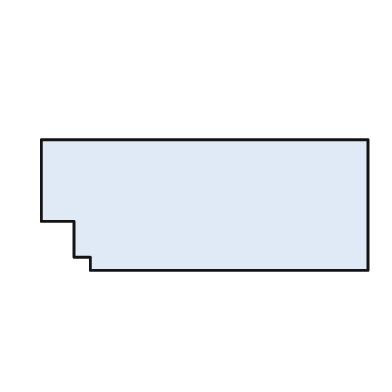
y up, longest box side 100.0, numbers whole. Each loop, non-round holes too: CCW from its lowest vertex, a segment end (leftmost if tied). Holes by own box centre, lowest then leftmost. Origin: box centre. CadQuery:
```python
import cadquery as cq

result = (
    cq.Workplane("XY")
    .moveTo(-35.0, -20.0)
    .lineTo(50.0, -20.0)
    .lineTo(50.0, 20.0)
    .lineTo(-50.0, 20.0)
    .lineTo(-50.0, -5.0)
    .lineTo(-40.0, -5.0)
    .lineTo(-40.0, -16.0)
    .lineTo(-35.0, -16.0)
    .close()
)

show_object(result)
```